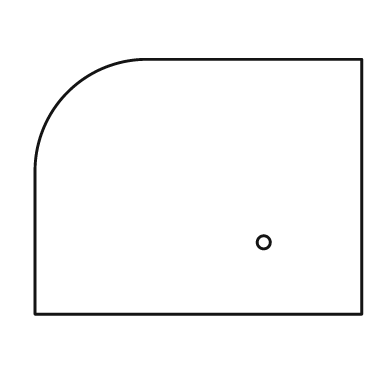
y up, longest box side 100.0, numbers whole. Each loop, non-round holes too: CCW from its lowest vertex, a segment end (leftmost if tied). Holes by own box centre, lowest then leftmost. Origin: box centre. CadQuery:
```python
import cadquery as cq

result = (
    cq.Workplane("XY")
    .moveTo(-50.0, -39.0)
    .lineTo(50.0, -39.0)
    .lineTo(50.0, 39.0)
    .lineTo(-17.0, 39.0)
    .threePointArc((-40.0, 29.0), (-50.0, 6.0))
    .close()
    .moveTo(20.0, -17.0)
    .circle(2.0)
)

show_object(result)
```